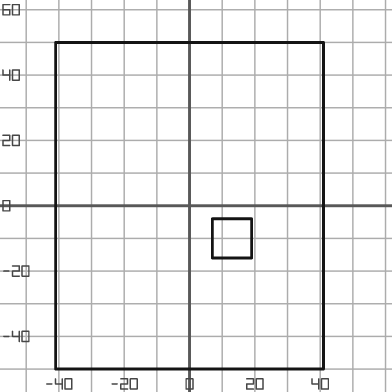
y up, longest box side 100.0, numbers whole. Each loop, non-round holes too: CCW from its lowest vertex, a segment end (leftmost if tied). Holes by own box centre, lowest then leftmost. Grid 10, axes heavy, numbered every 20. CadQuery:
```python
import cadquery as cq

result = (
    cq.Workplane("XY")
    .moveTo(-41.0, -50.0)
    .lineTo(41.0, -50.0)
    .lineTo(41.0, 50.0)
    .lineTo(-41.0, 50.0)
    .close()
    .moveTo(7.0, -16.0)
    .lineTo(19.0, -16.0)
    .lineTo(19.0, -4.0)
    .lineTo(7.0, -4.0)
    .close()
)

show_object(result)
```